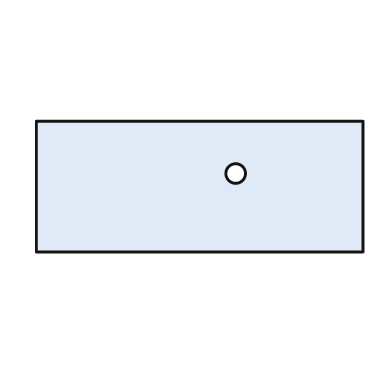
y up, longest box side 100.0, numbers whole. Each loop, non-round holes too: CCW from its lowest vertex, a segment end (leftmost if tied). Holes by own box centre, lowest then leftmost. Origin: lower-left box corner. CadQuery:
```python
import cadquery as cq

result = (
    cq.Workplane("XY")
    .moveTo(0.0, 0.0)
    .lineTo(100.0, 0.0)
    .lineTo(100.0, 40.0)
    .lineTo(0.0, 40.0)
    .close()
    .moveTo(61.0, 24.0)
    .circle(3.0)
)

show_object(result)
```